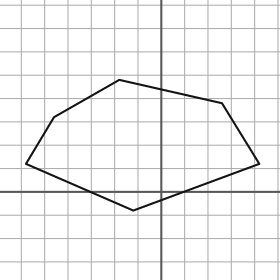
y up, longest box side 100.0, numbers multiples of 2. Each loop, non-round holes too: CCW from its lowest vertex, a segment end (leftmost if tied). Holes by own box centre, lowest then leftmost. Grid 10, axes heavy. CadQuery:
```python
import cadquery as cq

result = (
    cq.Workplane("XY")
    .moveTo(-12.0, -8.0)
    .lineTo(42.0, 12.0)
    .lineTo(26.0, 38.0)
    .lineTo(-18.0, 48.0)
    .lineTo(-46.0, 32.0)
    .lineTo(-58.0, 12.0)
    .close()
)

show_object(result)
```